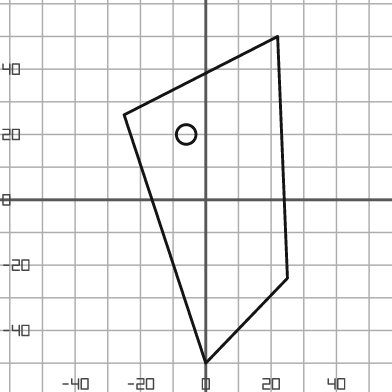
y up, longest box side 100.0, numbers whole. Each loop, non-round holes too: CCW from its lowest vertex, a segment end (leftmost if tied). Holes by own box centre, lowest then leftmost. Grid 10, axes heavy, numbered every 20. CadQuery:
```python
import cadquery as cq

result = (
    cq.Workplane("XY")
    .moveTo(0.0, -50.0)
    .lineTo(25.0, -24.0)
    .lineTo(22.0, 50.0)
    .lineTo(-25.0, 26.0)
    .close()
    .moveTo(-6.0, 20.0)
    .circle(3.0)
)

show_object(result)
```